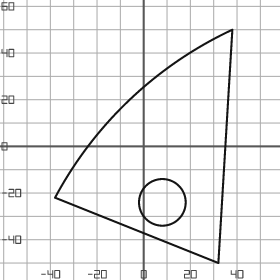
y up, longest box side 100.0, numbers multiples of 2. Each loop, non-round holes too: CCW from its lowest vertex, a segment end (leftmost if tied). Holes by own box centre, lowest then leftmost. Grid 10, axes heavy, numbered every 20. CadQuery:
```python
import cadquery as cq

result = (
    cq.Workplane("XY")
    .moveTo(32.0, -50.0)
    .lineTo(38.0, 50.0)
    .threePointArc((-6.0, 20.0), (-38.0, -22.0))
    .close()
    .moveTo(8.0, -24.0)
    .circle(10.0)
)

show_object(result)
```